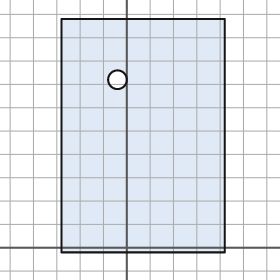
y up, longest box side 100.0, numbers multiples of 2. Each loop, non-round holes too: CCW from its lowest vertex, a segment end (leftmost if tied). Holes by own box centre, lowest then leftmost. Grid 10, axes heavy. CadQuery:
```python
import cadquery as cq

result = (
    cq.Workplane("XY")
    .moveTo(-28.0, -2.0)
    .lineTo(42.0, -2.0)
    .lineTo(42.0, 98.0)
    .lineTo(-28.0, 98.0)
    .close()
    .moveTo(-4.0, 72.0)
    .circle(4.0)
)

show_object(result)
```